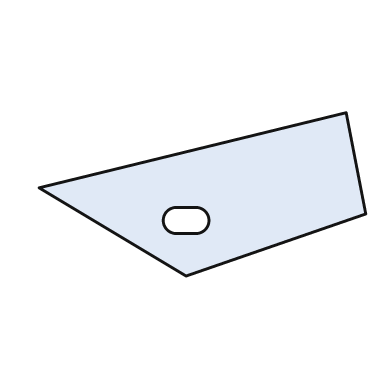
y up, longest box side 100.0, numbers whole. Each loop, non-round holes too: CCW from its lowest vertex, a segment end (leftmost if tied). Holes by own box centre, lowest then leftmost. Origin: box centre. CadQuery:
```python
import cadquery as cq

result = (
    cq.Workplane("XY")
    .moveTo(-5.0, -25.0)
    .lineTo(50.0, -6.0)
    .lineTo(44.0, 25.0)
    .lineTo(-50.0, 2.0)
    .close()
    .moveTo(-8.0, -12.0)
    .lineTo(-2.0, -12.0)
    .threePointArc((2.0, -8.0), (-2.0, -4.0))
    .lineTo(-8.0, -4.0)
    .threePointArc((-12.0, -8.0), (-8.0, -12.0))
    .close()
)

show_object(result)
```